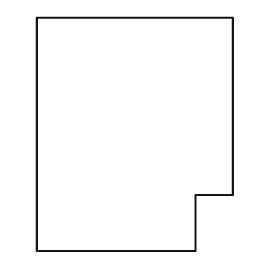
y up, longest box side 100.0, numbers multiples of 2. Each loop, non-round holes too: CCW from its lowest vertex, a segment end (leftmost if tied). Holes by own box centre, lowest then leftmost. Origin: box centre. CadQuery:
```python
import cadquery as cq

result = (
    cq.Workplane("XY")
    .moveTo(-42.0, -50.0)
    .lineTo(26.0, -50.0)
    .lineTo(26.0, -26.0)
    .lineTo(42.0, -26.0)
    .lineTo(42.0, 50.0)
    .lineTo(-42.0, 50.0)
    .close()
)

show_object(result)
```